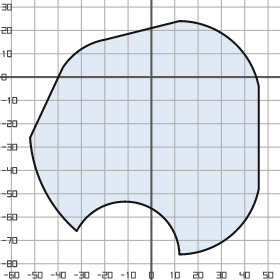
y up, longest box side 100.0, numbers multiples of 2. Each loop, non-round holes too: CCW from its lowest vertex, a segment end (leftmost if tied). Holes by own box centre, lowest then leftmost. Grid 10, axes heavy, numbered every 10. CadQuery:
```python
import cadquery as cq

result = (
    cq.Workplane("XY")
    .moveTo(12.0, -76.0)
    .threePointArc((34.0, -68.0), (46.0, -48.0))
    .lineTo(46.0, -4.0)
    .threePointArc((34.0, 16.0), (12.0, 24.0))
    .lineTo(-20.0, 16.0)
    .threePointArc((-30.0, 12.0), (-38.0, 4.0))
    .lineTo(-52.0, -26.0)
    .threePointArc((-46.0, -48.0), (-32.0, -66.0))
    .threePointArc((-6.0, -54.0), (12.0, -76.0))
    .close()
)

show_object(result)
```